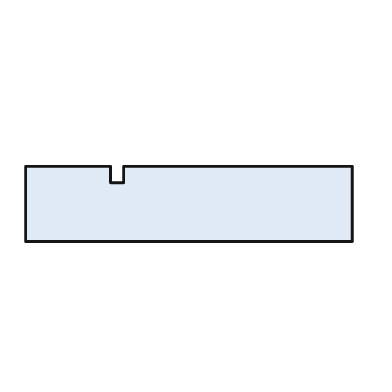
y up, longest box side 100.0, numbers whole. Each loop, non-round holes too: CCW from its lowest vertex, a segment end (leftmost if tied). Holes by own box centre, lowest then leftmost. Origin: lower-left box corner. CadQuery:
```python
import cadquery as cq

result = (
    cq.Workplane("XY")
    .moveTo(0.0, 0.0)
    .lineTo(100.0, 0.0)
    .lineTo(100.0, 23.0)
    .lineTo(30.0, 23.0)
    .lineTo(30.0, 18.0)
    .lineTo(26.0, 18.0)
    .lineTo(26.0, 23.0)
    .lineTo(0.0, 23.0)
    .close()
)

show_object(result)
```